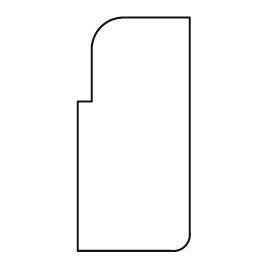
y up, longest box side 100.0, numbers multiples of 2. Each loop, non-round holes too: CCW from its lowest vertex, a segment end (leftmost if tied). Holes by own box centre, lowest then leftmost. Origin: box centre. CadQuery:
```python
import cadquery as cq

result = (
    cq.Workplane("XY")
    .moveTo(-24.0, -50.0)
    .lineTo(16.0, -50.0)
    .threePointArc((22.0, -48.0), (24.0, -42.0))
    .lineTo(24.0, 50.0)
    .lineTo(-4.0, 50.0)
    .threePointArc((-14.0, 46.0), (-18.0, 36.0))
    .lineTo(-18.0, 14.0)
    .lineTo(-24.0, 14.0)
    .close()
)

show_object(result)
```